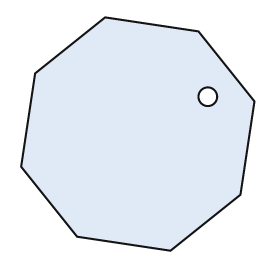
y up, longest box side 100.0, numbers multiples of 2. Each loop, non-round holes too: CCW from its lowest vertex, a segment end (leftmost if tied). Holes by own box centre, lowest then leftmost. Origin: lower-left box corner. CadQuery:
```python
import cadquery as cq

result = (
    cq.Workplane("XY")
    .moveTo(64.0, 0.0)
    .lineTo(94.0, 24.0)
    .lineTo(100.0, 64.0)
    .lineTo(76.0, 94.0)
    .lineTo(36.0, 100.0)
    .lineTo(6.0, 76.0)
    .lineTo(0.0, 36.0)
    .lineTo(24.0, 6.0)
    .close()
    .moveTo(80.0, 66.0)
    .circle(4.0)
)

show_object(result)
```